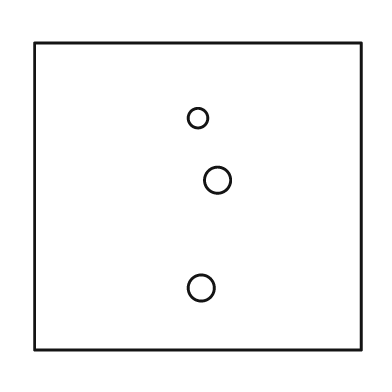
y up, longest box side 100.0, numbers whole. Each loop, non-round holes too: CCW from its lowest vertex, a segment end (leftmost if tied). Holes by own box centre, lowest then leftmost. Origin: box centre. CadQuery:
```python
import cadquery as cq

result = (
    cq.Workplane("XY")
    .moveTo(-50.0, -47.0)
    .lineTo(50.0, -47.0)
    .lineTo(50.0, 47.0)
    .lineTo(-50.0, 47.0)
    .close()
    .moveTo(1.0, -28.0)
    .circle(4.0)
    .moveTo(6.0, 5.0)
    .circle(4.0)
    .moveTo(0.0, 24.0)
    .circle(3.0)
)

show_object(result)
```